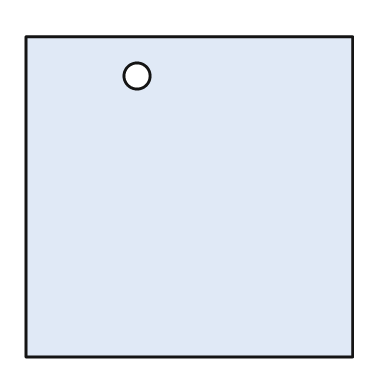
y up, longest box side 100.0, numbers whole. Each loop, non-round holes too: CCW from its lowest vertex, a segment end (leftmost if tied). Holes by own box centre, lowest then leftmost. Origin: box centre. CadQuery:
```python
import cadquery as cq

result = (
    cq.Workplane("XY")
    .moveTo(-50.0, -49.0)
    .lineTo(50.0, -49.0)
    .lineTo(50.0, 49.0)
    .lineTo(-50.0, 49.0)
    .close()
    .moveTo(-16.0, 37.0)
    .circle(4.0)
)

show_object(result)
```